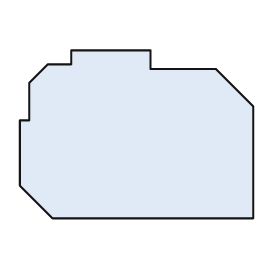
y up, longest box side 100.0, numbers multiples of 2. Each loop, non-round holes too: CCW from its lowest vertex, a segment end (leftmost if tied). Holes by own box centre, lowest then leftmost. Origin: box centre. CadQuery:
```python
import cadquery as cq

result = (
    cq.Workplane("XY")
    .moveTo(-36.0, -36.0)
    .lineTo(50.0, -36.0)
    .lineTo(50.0, 12.0)
    .lineTo(34.0, 28.0)
    .lineTo(6.0, 28.0)
    .lineTo(6.0, 36.0)
    .lineTo(-28.0, 36.0)
    .lineTo(-28.0, 30.0)
    .lineTo(-38.0, 30.0)
    .lineTo(-46.0, 22.0)
    .lineTo(-46.0, 6.0)
    .lineTo(-50.0, 6.0)
    .lineTo(-50.0, -22.0)
    .close()
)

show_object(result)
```